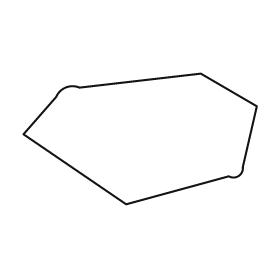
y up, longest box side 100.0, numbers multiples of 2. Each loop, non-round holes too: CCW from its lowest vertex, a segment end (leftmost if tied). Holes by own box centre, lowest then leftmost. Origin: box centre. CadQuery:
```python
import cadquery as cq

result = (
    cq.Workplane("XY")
    .moveTo(-6.0, -28.0)
    .lineTo(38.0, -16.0)
    .threePointArc((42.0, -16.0), (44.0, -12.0))
    .lineTo(50.0, 14.0)
    .lineTo(26.0, 28.0)
    .lineTo(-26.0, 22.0)
    .threePointArc((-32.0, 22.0), (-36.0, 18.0))
    .lineTo(-50.0, 2.0)
    .close()
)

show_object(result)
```